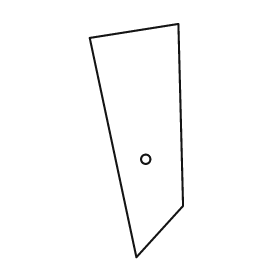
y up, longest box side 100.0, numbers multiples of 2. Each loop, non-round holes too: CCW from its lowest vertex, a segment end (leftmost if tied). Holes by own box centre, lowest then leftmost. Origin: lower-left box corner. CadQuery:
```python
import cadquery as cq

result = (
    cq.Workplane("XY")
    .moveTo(20.0, 0.0)
    .lineTo(40.0, 22.0)
    .lineTo(38.0, 100.0)
    .lineTo(0.0, 94.0)
    .close()
    .moveTo(24.0, 42.0)
    .circle(2.0)
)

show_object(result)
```